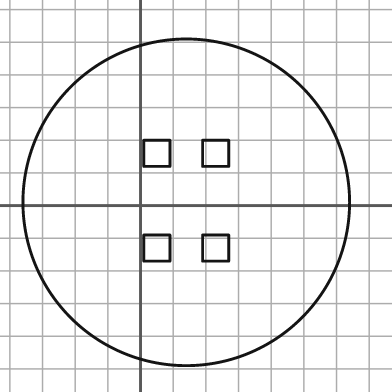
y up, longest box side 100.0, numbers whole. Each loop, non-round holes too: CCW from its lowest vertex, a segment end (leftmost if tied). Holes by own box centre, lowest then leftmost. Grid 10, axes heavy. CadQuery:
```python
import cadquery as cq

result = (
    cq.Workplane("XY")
    .moveTo(14.0, 1.0)
    .circle(50.0)
    .moveTo(1.0, -17.0)
    .lineTo(9.0, -17.0)
    .lineTo(9.0, -9.0)
    .lineTo(1.0, -9.0)
    .close()
    .moveTo(19.0, -17.0)
    .lineTo(27.0, -17.0)
    .lineTo(27.0, -9.0)
    .lineTo(19.0, -9.0)
    .close()
    .moveTo(1.0, 12.0)
    .lineTo(9.0, 12.0)
    .lineTo(9.0, 20.0)
    .lineTo(1.0, 20.0)
    .close()
    .moveTo(19.0, 12.0)
    .lineTo(27.0, 12.0)
    .lineTo(27.0, 20.0)
    .lineTo(19.0, 20.0)
    .close()
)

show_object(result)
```